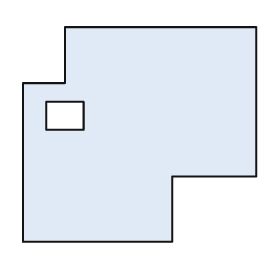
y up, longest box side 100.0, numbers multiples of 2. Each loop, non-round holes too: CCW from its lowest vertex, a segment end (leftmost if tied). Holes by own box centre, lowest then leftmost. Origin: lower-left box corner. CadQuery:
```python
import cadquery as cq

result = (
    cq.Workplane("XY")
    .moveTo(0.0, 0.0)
    .lineTo(64.0, 0.0)
    .lineTo(64.0, 28.0)
    .lineTo(100.0, 28.0)
    .lineTo(100.0, 92.0)
    .lineTo(18.0, 92.0)
    .lineTo(18.0, 68.0)
    .lineTo(0.0, 68.0)
    .close()
    .moveTo(10.0, 48.0)
    .lineTo(26.0, 48.0)
    .lineTo(26.0, 60.0)
    .lineTo(10.0, 60.0)
    .close()
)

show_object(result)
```